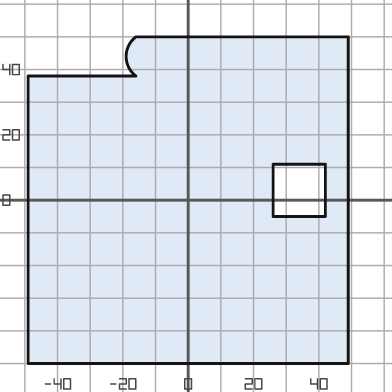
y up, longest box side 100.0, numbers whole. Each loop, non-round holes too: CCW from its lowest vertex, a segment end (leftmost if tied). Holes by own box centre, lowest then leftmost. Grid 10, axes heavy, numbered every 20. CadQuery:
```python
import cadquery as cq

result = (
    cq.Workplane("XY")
    .moveTo(-49.0, -50.0)
    .lineTo(49.0, -50.0)
    .lineTo(49.0, 50.0)
    .lineTo(-16.0, 50.0)
    .threePointArc((-19.0, 44.0), (-16.0, 38.0))
    .lineTo(-49.0, 38.0)
    .close()
    .moveTo(26.0, -5.0)
    .lineTo(42.0, -5.0)
    .lineTo(42.0, 11.0)
    .lineTo(26.0, 11.0)
    .close()
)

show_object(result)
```